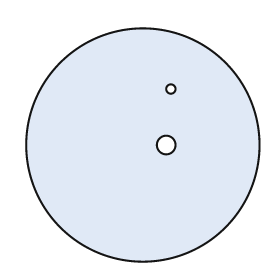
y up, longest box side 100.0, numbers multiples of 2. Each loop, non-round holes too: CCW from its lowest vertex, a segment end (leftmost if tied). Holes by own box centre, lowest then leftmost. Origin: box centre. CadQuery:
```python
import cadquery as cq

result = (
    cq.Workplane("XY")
    .moveTo(0.0, 0.0)
    .circle(50.0)
    .moveTo(10.0, 0.0)
    .circle(4.0)
    .moveTo(12.0, 24.0)
    .circle(2.0)
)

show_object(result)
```